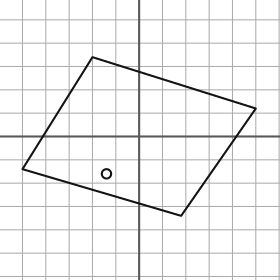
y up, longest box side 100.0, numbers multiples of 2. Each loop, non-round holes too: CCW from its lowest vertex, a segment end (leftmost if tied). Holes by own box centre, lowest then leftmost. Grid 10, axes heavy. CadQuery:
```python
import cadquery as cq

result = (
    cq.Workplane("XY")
    .moveTo(18.0, -34.0)
    .lineTo(50.0, 12.0)
    .lineTo(-20.0, 34.0)
    .lineTo(-50.0, -14.0)
    .close()
    .moveTo(-14.0, -16.0)
    .circle(2.0)
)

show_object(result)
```